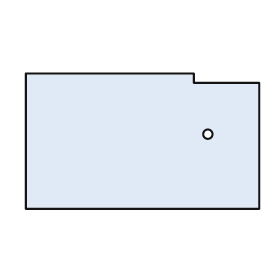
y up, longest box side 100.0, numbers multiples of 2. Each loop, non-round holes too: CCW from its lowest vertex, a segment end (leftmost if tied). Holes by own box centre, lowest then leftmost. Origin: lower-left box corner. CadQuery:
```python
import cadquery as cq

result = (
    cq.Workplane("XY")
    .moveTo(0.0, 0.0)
    .lineTo(100.0, 0.0)
    .lineTo(100.0, 54.0)
    .lineTo(72.0, 54.0)
    .lineTo(72.0, 58.0)
    .lineTo(0.0, 58.0)
    .close()
    .moveTo(78.0, 32.0)
    .circle(2.0)
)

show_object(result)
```